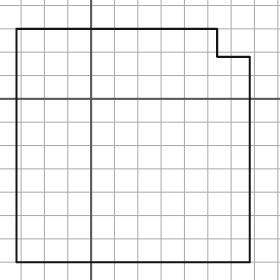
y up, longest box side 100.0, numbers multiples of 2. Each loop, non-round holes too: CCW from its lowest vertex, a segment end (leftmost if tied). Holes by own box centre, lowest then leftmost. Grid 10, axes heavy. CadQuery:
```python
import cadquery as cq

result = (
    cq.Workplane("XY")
    .moveTo(-32.0, -70.0)
    .lineTo(68.0, -70.0)
    .lineTo(68.0, 18.0)
    .lineTo(54.0, 18.0)
    .lineTo(54.0, 30.0)
    .lineTo(-32.0, 30.0)
    .close()
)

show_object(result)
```